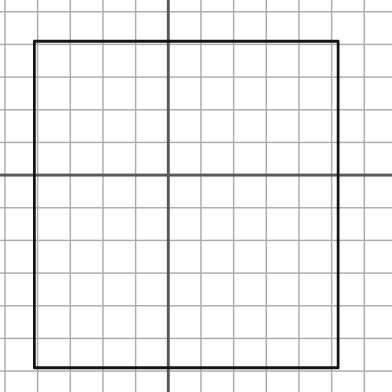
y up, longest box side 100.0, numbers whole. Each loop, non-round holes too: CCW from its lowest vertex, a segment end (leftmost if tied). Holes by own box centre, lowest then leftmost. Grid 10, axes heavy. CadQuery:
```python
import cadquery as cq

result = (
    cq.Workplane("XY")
    .moveTo(-41.0, -59.0)
    .lineTo(52.0, -59.0)
    .lineTo(52.0, 41.0)
    .lineTo(-41.0, 41.0)
    .close()
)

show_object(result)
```